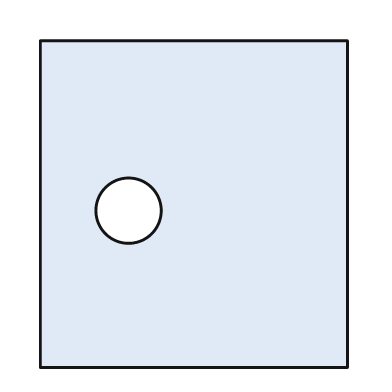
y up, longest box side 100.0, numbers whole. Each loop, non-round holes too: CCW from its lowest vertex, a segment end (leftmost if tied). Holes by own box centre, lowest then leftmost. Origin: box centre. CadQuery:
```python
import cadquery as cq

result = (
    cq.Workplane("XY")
    .moveTo(-47.0, -50.0)
    .lineTo(47.0, -50.0)
    .lineTo(47.0, 50.0)
    .lineTo(-47.0, 50.0)
    .close()
    .moveTo(-20.0, -2.0)
    .circle(10.0)
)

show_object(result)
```